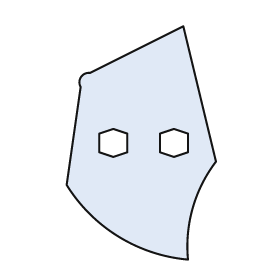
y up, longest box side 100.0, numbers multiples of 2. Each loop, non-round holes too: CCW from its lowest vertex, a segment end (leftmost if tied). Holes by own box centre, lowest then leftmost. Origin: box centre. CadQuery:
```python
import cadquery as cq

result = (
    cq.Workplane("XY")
    .moveTo(20.0, -50.0)
    .threePointArc((22.0, -28.0), (32.0, -8.0))
    .lineTo(18.0, 50.0)
    .lineTo(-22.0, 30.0)
    .threePointArc((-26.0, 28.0), (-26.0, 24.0))
    .lineTo(-32.0, -18.0)
    .threePointArc((-10.0, -40.0), (20.0, -50.0))
    .close()
    .moveTo(-12.0, -6.0)
    .lineTo(-6.0, -4.0)
    .lineTo(-6.0, 4.0)
    .lineTo(-12.0, 6.0)
    .lineTo(-18.0, 4.0)
    .lineTo(-18.0, -4.0)
    .close()
    .moveTo(14.0, -6.0)
    .lineTo(20.0, -4.0)
    .lineTo(20.0, 4.0)
    .lineTo(14.0, 6.0)
    .lineTo(8.0, 4.0)
    .lineTo(8.0, -4.0)
    .close()
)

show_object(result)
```